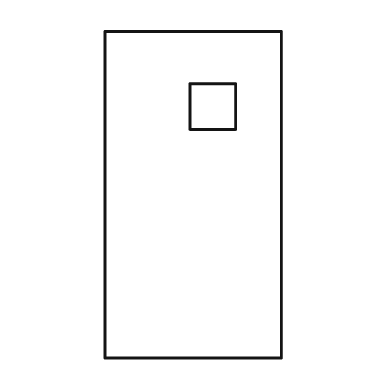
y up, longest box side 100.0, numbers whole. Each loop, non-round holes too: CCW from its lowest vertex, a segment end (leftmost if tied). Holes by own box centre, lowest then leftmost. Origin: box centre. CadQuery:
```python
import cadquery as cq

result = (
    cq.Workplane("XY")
    .moveTo(-27.0, -50.0)
    .lineTo(27.0, -50.0)
    .lineTo(27.0, 50.0)
    .lineTo(-27.0, 50.0)
    .close()
    .moveTo(-1.0, 20.0)
    .lineTo(13.0, 20.0)
    .lineTo(13.0, 34.0)
    .lineTo(-1.0, 34.0)
    .close()
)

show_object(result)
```